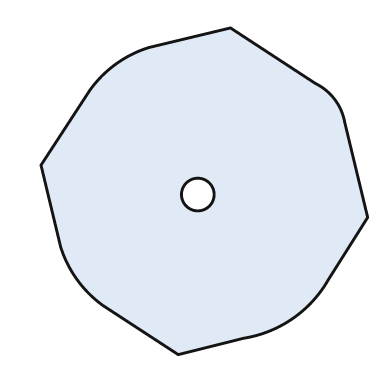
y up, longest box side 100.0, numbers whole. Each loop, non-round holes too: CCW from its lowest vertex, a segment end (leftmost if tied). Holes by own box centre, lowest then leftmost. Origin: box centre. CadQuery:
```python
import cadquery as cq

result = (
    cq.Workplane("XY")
    .moveTo(-8.0, -50.0)
    .lineTo(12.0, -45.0)
    .threePointArc((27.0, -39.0), (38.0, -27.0))
    .lineTo(50.0, -8.0)
    .lineTo(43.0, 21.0)
    .threePointArc((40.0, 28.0), (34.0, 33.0))
    .lineTo(8.0, 50.0)
    .lineTo(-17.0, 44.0)
    .threePointArc((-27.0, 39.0), (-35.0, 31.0))
    .lineTo(-50.0, 8.0)
    .lineTo(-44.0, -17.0)
    .threePointArc((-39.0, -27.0), (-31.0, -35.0))
    .close()
    .moveTo(-2.0, -1.0)
    .circle(5.0)
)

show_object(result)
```